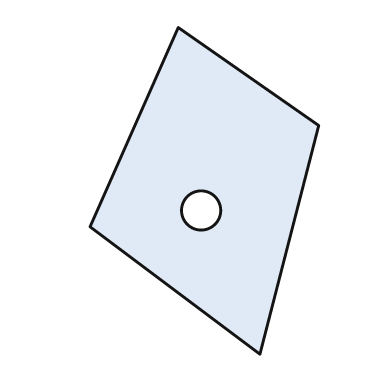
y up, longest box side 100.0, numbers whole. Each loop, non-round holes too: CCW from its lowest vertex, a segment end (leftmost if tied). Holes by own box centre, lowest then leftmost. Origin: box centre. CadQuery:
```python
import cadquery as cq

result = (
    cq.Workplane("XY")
    .moveTo(17.0, -50.0)
    .lineTo(35.0, 20.0)
    .lineTo(-8.0, 50.0)
    .lineTo(-35.0, -11.0)
    .close()
    .moveTo(-1.0, -6.0)
    .circle(6.0)
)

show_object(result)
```